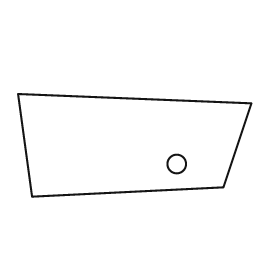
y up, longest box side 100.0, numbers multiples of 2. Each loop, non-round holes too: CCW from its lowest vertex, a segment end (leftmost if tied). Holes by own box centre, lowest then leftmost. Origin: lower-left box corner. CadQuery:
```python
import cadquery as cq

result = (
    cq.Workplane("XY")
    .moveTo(6.0, 0.0)
    .lineTo(88.0, 4.0)
    .lineTo(100.0, 40.0)
    .lineTo(0.0, 44.0)
    .close()
    .moveTo(68.0, 14.0)
    .circle(4.0)
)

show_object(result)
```